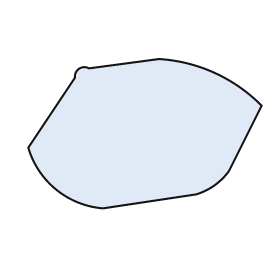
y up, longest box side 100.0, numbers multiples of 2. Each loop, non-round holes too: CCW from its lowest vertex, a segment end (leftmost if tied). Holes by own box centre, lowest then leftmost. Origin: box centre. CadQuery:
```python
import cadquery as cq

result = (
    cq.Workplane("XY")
    .moveTo(-18.0, -32.0)
    .lineTo(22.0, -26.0)
    .threePointArc((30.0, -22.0), (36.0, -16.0))
    .lineTo(50.0, 12.0)
    .threePointArc((30.0, 26.0), (6.0, 32.0))
    .lineTo(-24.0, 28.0)
    .threePointArc((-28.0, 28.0), (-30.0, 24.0))
    .lineTo(-50.0, -6.0)
    .threePointArc((-38.0, -24.0), (-18.0, -32.0))
    .close()
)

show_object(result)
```